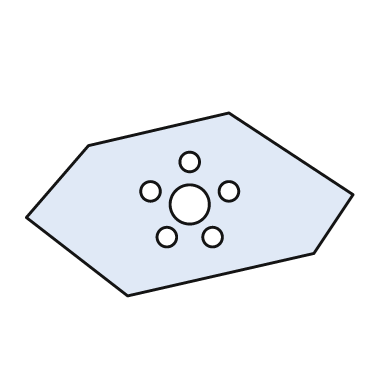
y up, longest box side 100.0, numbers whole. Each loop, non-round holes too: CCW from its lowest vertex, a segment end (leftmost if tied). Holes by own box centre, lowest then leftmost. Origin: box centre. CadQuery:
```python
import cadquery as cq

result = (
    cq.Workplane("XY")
    .moveTo(-19.0, -28.0)
    .lineTo(38.0, -15.0)
    .lineTo(50.0, 3.0)
    .lineTo(12.0, 28.0)
    .lineTo(-31.0, 18.0)
    .lineTo(-50.0, -4.0)
    .close()
    .moveTo(-7.0, -10.0)
    .circle(3.0)
    .moveTo(7.0, -10.0)
    .circle(3.0)
    .moveTo(0.0, 0.0)
    .circle(6.0)
    .moveTo(-12.0, 4.0)
    .circle(3.0)
    .moveTo(12.0, 4.0)
    .circle(3.0)
    .moveTo(0.0, 13.0)
    .circle(3.0)
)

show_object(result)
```